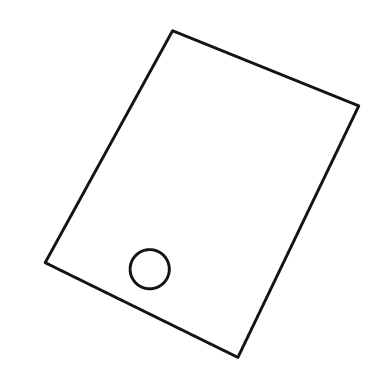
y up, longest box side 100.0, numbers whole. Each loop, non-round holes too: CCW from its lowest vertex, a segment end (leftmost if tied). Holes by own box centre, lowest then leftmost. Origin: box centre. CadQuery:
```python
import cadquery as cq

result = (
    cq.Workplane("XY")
    .moveTo(11.0, -50.0)
    .lineTo(48.0, 27.0)
    .lineTo(-9.0, 50.0)
    .lineTo(-48.0, -21.0)
    .close()
    .moveTo(-16.0, -23.0)
    .circle(6.0)
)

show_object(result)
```